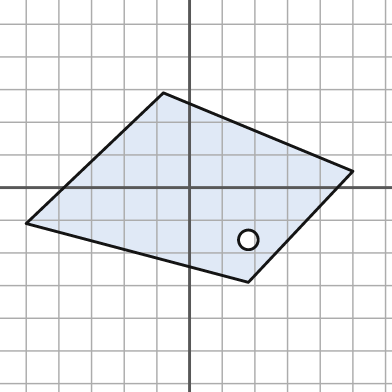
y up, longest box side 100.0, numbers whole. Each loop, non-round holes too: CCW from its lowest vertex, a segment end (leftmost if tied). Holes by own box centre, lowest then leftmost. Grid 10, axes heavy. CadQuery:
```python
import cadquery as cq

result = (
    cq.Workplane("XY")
    .moveTo(18.0, -29.0)
    .lineTo(50.0, 5.0)
    .lineTo(-8.0, 29.0)
    .lineTo(-50.0, -11.0)
    .close()
    .moveTo(18.0, -16.0)
    .circle(3.0)
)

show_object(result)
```